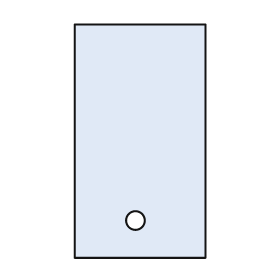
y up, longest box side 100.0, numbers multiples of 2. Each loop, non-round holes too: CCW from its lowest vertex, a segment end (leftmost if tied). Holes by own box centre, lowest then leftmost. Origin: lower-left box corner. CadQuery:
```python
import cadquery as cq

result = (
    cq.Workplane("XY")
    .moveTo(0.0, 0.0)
    .lineTo(56.0, 0.0)
    .lineTo(56.0, 100.0)
    .lineTo(0.0, 100.0)
    .close()
    .moveTo(26.0, 16.0)
    .circle(4.0)
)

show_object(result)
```